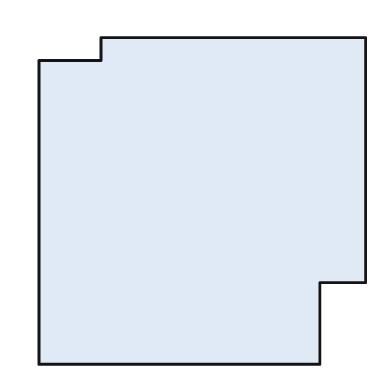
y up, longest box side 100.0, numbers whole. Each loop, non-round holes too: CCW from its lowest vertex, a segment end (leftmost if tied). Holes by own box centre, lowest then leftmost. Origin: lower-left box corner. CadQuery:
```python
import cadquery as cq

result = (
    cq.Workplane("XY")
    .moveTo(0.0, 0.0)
    .lineTo(86.0, 0.0)
    .lineTo(86.0, 25.0)
    .lineTo(100.0, 25.0)
    .lineTo(100.0, 100.0)
    .lineTo(19.0, 100.0)
    .lineTo(19.0, 93.0)
    .lineTo(0.0, 93.0)
    .close()
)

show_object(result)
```